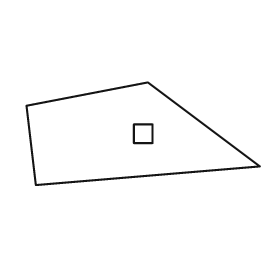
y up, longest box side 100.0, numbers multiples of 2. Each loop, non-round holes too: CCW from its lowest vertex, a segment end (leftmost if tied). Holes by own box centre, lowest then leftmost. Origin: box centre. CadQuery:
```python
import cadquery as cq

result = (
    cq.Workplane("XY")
    .moveTo(-46.0, -22.0)
    .lineTo(50.0, -14.0)
    .lineTo(2.0, 22.0)
    .lineTo(-50.0, 12.0)
    .close()
    .moveTo(-4.0, -4.0)
    .lineTo(4.0, -4.0)
    .lineTo(4.0, 4.0)
    .lineTo(-4.0, 4.0)
    .close()
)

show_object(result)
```